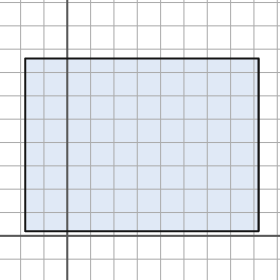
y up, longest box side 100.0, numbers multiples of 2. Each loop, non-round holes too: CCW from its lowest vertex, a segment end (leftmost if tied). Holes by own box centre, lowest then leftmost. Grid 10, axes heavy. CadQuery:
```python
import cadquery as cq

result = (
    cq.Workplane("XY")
    .moveTo(-18.0, 2.0)
    .lineTo(82.0, 2.0)
    .lineTo(82.0, 76.0)
    .lineTo(-18.0, 76.0)
    .close()
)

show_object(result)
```